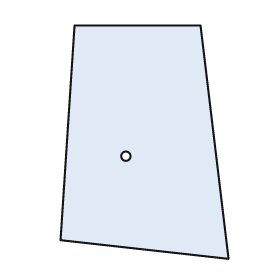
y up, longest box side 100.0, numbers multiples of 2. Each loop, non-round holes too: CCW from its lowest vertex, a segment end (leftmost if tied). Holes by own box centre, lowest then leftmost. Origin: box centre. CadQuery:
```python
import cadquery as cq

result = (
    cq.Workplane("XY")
    .moveTo(36.0, -50.0)
    .lineTo(24.0, 50.0)
    .lineTo(-30.0, 50.0)
    .lineTo(-36.0, -42.0)
    .close()
    .moveTo(-8.0, -6.0)
    .circle(2.0)
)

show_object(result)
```